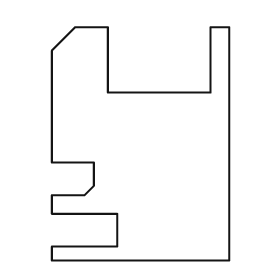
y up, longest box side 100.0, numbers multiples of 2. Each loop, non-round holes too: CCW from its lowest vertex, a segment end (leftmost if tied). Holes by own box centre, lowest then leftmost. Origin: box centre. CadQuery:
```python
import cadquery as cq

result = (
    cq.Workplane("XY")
    .moveTo(-38.0, -50.0)
    .lineTo(38.0, -50.0)
    .lineTo(38.0, 50.0)
    .lineTo(30.0, 50.0)
    .lineTo(30.0, 22.0)
    .lineTo(-14.0, 22.0)
    .lineTo(-14.0, 50.0)
    .lineTo(-28.0, 50.0)
    .lineTo(-38.0, 40.0)
    .lineTo(-38.0, -8.0)
    .lineTo(-20.0, -8.0)
    .lineTo(-20.0, -18.0)
    .lineTo(-24.0, -22.0)
    .lineTo(-38.0, -22.0)
    .lineTo(-38.0, -30.0)
    .lineTo(-10.0, -30.0)
    .lineTo(-10.0, -44.0)
    .lineTo(-38.0, -44.0)
    .close()
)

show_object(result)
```